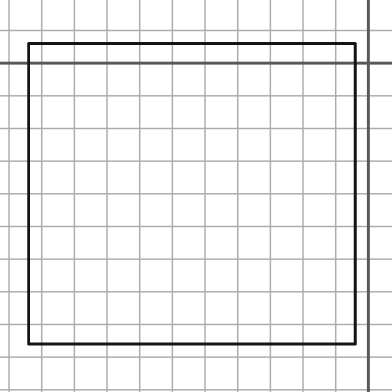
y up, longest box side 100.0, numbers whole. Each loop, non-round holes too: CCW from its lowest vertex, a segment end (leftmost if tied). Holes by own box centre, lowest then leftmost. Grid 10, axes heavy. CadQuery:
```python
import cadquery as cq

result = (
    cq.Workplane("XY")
    .moveTo(-104.0, -86.0)
    .lineTo(-4.0, -86.0)
    .lineTo(-4.0, 6.0)
    .lineTo(-104.0, 6.0)
    .close()
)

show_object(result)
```